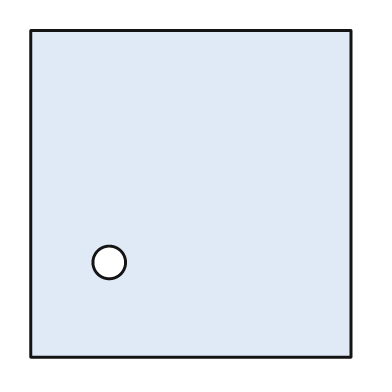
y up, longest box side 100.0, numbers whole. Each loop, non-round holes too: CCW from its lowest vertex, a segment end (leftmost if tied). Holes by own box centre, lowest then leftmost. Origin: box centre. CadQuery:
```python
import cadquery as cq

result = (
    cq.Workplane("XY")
    .moveTo(-49.0, -50.0)
    .lineTo(49.0, -50.0)
    .lineTo(49.0, 50.0)
    .lineTo(-49.0, 50.0)
    .close()
    .moveTo(-25.0, -21.0)
    .circle(5.0)
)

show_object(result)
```